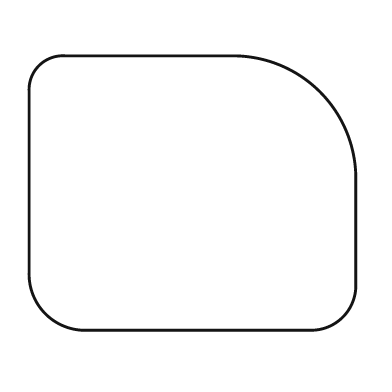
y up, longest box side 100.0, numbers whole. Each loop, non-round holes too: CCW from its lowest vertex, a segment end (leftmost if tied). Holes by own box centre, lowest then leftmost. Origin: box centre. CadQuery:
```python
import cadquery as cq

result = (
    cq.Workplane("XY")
    .moveTo(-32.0, -42.0)
    .lineTo(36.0, -42.0)
    .threePointArc((46.0, -38.0), (50.0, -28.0))
    .lineTo(50.0, 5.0)
    .threePointArc((39.0, 31.0), (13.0, 42.0))
    .lineTo(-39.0, 42.0)
    .threePointArc((-47.0, 39.0), (-50.0, 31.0))
    .lineTo(-50.0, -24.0)
    .threePointArc((-45.0, -37.0), (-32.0, -42.0))
    .close()
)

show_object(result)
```